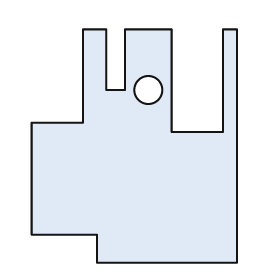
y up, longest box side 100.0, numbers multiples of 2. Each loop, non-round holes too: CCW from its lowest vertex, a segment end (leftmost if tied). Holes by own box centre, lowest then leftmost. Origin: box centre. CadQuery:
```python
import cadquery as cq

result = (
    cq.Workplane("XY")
    .moveTo(-16.0, -50.0)
    .lineTo(44.0, -50.0)
    .lineTo(44.0, 50.0)
    .lineTo(38.0, 50.0)
    .lineTo(38.0, 6.0)
    .lineTo(16.0, 6.0)
    .lineTo(16.0, 50.0)
    .lineTo(-4.0, 50.0)
    .lineTo(-4.0, 24.0)
    .lineTo(-12.0, 24.0)
    .lineTo(-12.0, 50.0)
    .lineTo(-22.0, 50.0)
    .lineTo(-22.0, 10.0)
    .lineTo(-44.0, 10.0)
    .lineTo(-44.0, -38.0)
    .lineTo(-16.0, -38.0)
    .close()
    .moveTo(6.0, 24.0)
    .circle(6.0)
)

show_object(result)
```